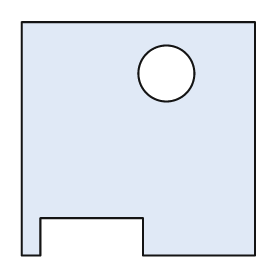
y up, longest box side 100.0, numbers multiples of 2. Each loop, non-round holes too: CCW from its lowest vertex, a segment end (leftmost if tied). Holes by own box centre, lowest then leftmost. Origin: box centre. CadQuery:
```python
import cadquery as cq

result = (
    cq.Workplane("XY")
    .moveTo(-50.0, -50.0)
    .lineTo(-42.0, -50.0)
    .lineTo(-42.0, -34.0)
    .lineTo(2.0, -34.0)
    .lineTo(2.0, -50.0)
    .lineTo(50.0, -50.0)
    .lineTo(50.0, 50.0)
    .lineTo(-50.0, 50.0)
    .close()
    .moveTo(12.0, 28.0)
    .circle(12.0)
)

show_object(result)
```